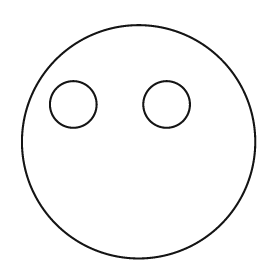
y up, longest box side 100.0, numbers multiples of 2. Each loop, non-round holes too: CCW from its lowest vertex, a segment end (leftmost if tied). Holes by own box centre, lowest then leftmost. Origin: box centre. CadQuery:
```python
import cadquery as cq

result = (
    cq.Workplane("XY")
    .moveTo(0.0, 0.0)
    .circle(50.0)
    .moveTo(-28.0, 16.0)
    .circle(10.0)
    .moveTo(12.0, 16.0)
    .circle(10.0)
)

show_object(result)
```